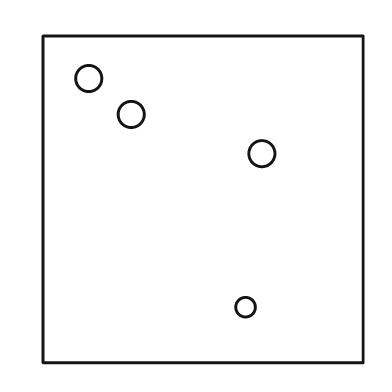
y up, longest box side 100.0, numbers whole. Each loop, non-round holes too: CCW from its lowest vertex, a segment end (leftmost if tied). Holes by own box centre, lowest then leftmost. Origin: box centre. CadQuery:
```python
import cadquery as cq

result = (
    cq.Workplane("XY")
    .moveTo(-49.0, -50.0)
    .lineTo(49.0, -50.0)
    .lineTo(49.0, 50.0)
    .lineTo(-49.0, 50.0)
    .close()
    .moveTo(13.0, -33.0)
    .circle(3.0)
    .moveTo(18.0, 14.0)
    .circle(4.0)
    .moveTo(-22.0, 26.0)
    .circle(4.0)
    .moveTo(-35.0, 37.0)
    .circle(4.0)
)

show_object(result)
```